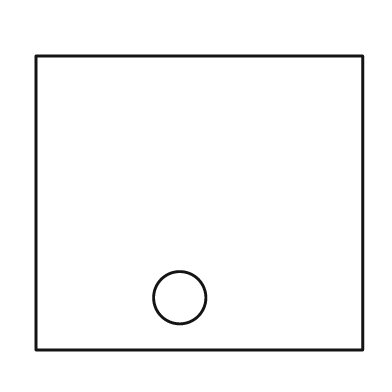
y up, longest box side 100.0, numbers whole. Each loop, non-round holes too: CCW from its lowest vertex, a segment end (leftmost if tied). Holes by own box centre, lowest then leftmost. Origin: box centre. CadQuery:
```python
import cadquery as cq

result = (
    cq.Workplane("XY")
    .moveTo(-50.0, -45.0)
    .lineTo(50.0, -45.0)
    .lineTo(50.0, 45.0)
    .lineTo(-50.0, 45.0)
    .close()
    .moveTo(-6.0, -29.0)
    .circle(8.0)
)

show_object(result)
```